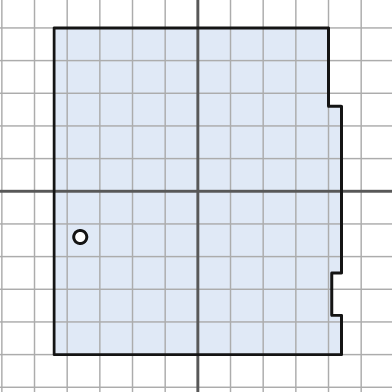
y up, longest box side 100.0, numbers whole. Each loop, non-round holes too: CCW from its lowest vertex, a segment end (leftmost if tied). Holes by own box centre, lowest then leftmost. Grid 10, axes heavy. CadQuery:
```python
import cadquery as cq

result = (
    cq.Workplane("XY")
    .moveTo(-44.0, -50.0)
    .lineTo(44.0, -50.0)
    .lineTo(44.0, -38.0)
    .lineTo(41.0, -38.0)
    .lineTo(41.0, -25.0)
    .lineTo(44.0, -25.0)
    .lineTo(44.0, 26.0)
    .lineTo(40.0, 26.0)
    .lineTo(40.0, 50.0)
    .lineTo(-44.0, 50.0)
    .close()
    .moveTo(-36.0, -14.0)
    .circle(2.0)
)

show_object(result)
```